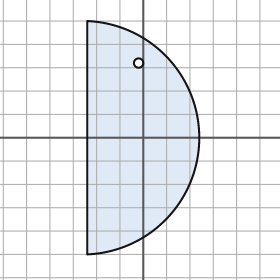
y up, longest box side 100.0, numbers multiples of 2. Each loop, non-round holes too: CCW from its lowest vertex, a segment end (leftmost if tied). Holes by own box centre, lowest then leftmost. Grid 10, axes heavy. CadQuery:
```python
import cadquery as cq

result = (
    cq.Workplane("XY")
    .moveTo(-24.0, -50.0)
    .threePointArc((24.0, 0.0), (-24.0, 50.0))
    .close()
    .moveTo(-2.0, 32.0)
    .circle(2.0)
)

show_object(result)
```